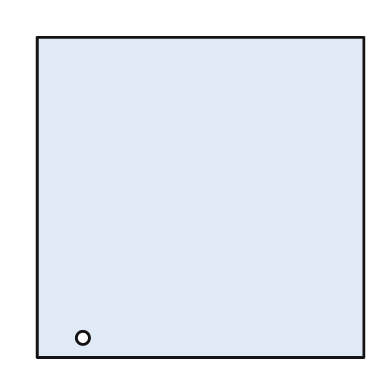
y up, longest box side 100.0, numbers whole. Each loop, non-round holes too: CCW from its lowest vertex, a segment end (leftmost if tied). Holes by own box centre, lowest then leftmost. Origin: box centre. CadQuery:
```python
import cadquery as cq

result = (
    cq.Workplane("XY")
    .moveTo(-50.0, -49.0)
    .lineTo(50.0, -49.0)
    .lineTo(50.0, 49.0)
    .lineTo(-50.0, 49.0)
    .close()
    .moveTo(-36.0, -43.0)
    .circle(2.0)
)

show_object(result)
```